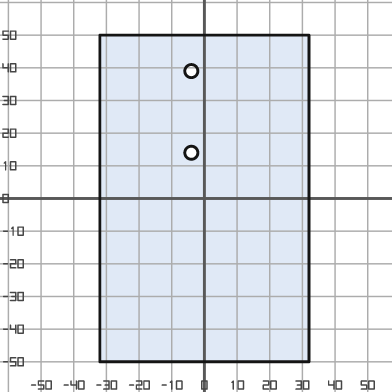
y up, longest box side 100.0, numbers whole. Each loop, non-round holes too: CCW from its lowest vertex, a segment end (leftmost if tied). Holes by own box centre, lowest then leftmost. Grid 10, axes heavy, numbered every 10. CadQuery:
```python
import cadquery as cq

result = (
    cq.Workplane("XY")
    .moveTo(-32.0, -50.0)
    .lineTo(32.0, -50.0)
    .lineTo(32.0, 50.0)
    .lineTo(-32.0, 50.0)
    .close()
    .moveTo(-4.0, 14.0)
    .circle(2.0)
    .moveTo(-4.0, 39.0)
    .circle(2.0)
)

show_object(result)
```